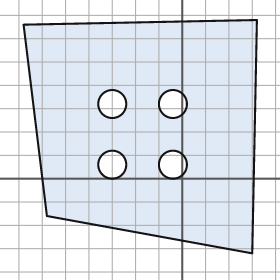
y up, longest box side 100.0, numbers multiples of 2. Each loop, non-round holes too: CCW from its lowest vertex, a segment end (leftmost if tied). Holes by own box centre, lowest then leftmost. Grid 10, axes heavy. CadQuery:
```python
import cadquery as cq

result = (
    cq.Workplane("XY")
    .moveTo(30.0, -32.0)
    .lineTo(32.0, 68.0)
    .lineTo(-68.0, 66.0)
    .lineTo(-58.0, -16.0)
    .close()
    .moveTo(-30.0, 6.0)
    .circle(6.0)
    .moveTo(-4.0, 6.0)
    .circle(6.0)
    .moveTo(-30.0, 32.0)
    .circle(6.0)
    .moveTo(-4.0, 32.0)
    .circle(6.0)
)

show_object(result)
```